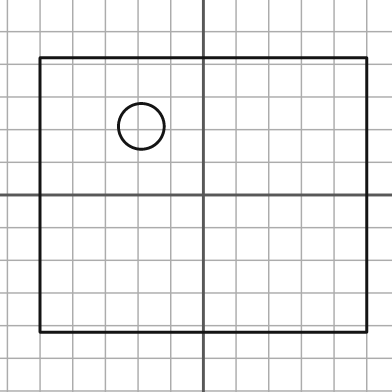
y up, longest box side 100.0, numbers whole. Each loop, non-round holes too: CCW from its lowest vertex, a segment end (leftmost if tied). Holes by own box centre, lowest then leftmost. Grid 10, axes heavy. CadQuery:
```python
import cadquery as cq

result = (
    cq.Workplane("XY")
    .moveTo(-50.0, -42.0)
    .lineTo(50.0, -42.0)
    .lineTo(50.0, 42.0)
    .lineTo(-50.0, 42.0)
    .close()
    .moveTo(-19.0, 21.0)
    .circle(7.0)
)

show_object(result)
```